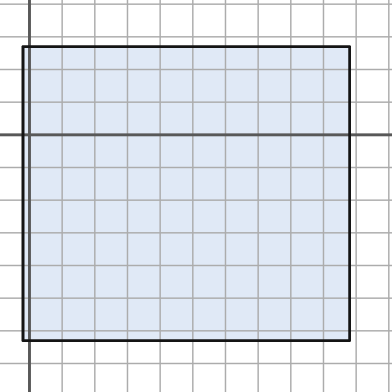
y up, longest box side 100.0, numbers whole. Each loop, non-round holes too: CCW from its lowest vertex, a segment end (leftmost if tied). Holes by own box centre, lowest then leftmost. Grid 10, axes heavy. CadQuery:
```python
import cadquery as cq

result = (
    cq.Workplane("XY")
    .moveTo(-2.0, -63.0)
    .lineTo(98.0, -63.0)
    .lineTo(98.0, 27.0)
    .lineTo(-2.0, 27.0)
    .close()
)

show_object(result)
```